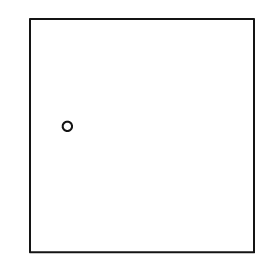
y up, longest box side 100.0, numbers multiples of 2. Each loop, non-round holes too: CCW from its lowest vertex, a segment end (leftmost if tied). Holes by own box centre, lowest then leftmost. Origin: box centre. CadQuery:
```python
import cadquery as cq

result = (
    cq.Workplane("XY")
    .moveTo(-48.0, -50.0)
    .lineTo(48.0, -50.0)
    .lineTo(48.0, 50.0)
    .lineTo(-48.0, 50.0)
    .close()
    .moveTo(-32.0, 4.0)
    .circle(2.0)
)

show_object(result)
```